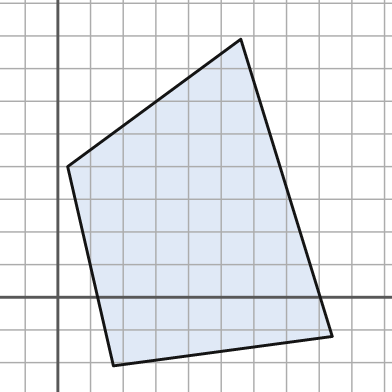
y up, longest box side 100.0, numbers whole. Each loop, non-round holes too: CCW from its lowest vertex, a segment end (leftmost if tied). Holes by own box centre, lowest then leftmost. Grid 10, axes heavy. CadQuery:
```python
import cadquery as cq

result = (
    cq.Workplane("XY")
    .moveTo(17.0, -21.0)
    .lineTo(84.0, -12.0)
    .lineTo(56.0, 79.0)
    .lineTo(3.0, 40.0)
    .close()
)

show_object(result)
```